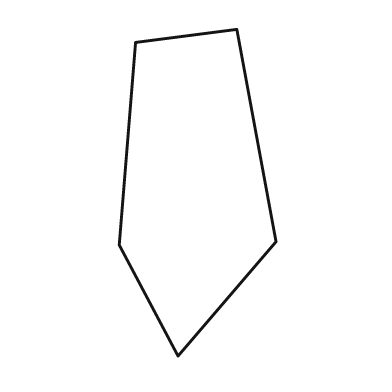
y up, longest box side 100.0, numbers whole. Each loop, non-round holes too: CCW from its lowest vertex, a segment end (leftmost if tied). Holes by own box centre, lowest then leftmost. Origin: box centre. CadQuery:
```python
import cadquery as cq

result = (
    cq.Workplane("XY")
    .moveTo(-6.0, -50.0)
    .lineTo(24.0, -15.0)
    .lineTo(12.0, 50.0)
    .lineTo(-19.0, 46.0)
    .lineTo(-24.0, -16.0)
    .close()
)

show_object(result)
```